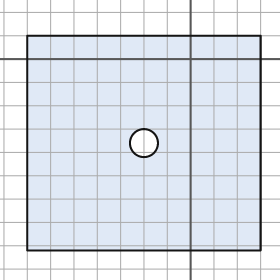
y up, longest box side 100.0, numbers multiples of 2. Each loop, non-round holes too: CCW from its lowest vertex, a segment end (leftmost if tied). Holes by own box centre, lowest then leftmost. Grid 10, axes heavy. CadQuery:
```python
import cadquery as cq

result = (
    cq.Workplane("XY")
    .moveTo(-70.0, -82.0)
    .lineTo(30.0, -82.0)
    .lineTo(30.0, 10.0)
    .lineTo(-70.0, 10.0)
    .close()
    .moveTo(-20.0, -36.0)
    .circle(6.0)
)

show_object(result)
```